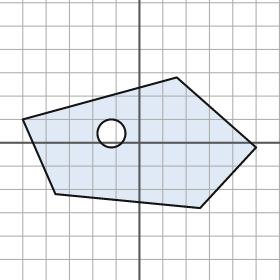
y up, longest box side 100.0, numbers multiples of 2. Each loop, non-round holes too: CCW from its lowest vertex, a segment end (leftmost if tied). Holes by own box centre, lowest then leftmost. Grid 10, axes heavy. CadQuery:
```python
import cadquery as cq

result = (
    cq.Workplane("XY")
    .moveTo(26.0, -28.0)
    .lineTo(50.0, -2.0)
    .lineTo(16.0, 28.0)
    .lineTo(-50.0, 10.0)
    .lineTo(-36.0, -22.0)
    .close()
    .moveTo(-12.0, 4.0)
    .circle(6.0)
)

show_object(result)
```